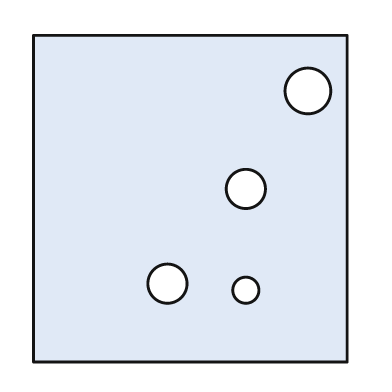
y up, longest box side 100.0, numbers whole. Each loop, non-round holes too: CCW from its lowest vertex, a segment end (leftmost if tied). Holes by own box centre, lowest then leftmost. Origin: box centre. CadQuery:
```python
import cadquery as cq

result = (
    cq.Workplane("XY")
    .moveTo(-48.0, -50.0)
    .lineTo(48.0, -50.0)
    .lineTo(48.0, 50.0)
    .lineTo(-48.0, 50.0)
    .close()
    .moveTo(17.0, -28.0)
    .circle(4.0)
    .moveTo(-7.0, -26.0)
    .circle(6.0)
    .moveTo(17.0, 3.0)
    .circle(6.0)
    .moveTo(36.0, 33.0)
    .circle(7.0)
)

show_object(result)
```